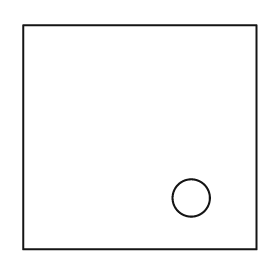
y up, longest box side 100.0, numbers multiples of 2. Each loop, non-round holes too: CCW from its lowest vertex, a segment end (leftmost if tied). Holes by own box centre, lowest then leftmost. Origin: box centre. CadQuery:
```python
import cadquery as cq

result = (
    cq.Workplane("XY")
    .moveTo(-50.0, -48.0)
    .lineTo(50.0, -48.0)
    .lineTo(50.0, 48.0)
    .lineTo(-50.0, 48.0)
    .close()
    .moveTo(22.0, -26.0)
    .circle(8.0)
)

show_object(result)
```